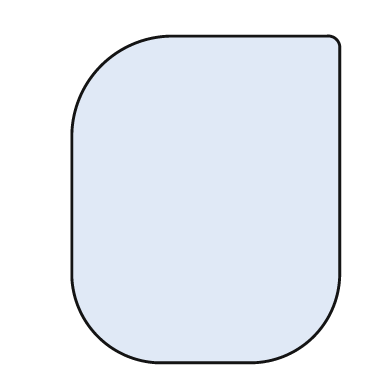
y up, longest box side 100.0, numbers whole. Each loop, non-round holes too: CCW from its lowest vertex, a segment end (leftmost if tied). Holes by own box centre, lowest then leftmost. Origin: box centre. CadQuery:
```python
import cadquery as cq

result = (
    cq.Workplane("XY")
    .moveTo(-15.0, -50.0)
    .lineTo(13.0, -50.0)
    .threePointArc((33.0, -42.0), (41.0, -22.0))
    .lineTo(41.0, 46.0)
    .threePointArc((40.0, 49.0), (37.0, 50.0))
    .lineTo(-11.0, 50.0)
    .threePointArc((-32.0, 41.0), (-41.0, 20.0))
    .lineTo(-41.0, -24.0)
    .threePointArc((-33.0, -42.0), (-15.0, -50.0))
    .close()
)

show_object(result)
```